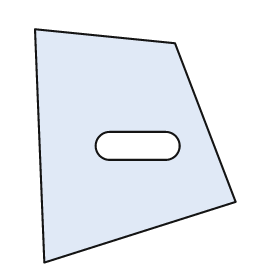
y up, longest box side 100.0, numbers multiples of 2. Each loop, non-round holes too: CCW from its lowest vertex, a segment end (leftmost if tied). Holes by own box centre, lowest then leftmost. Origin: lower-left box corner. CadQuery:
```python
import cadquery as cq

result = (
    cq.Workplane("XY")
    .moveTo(4.0, 0.0)
    .lineTo(86.0, 26.0)
    .lineTo(60.0, 94.0)
    .lineTo(0.0, 100.0)
    .close()
    .moveTo(32.0, 44.0)
    .lineTo(56.0, 44.0)
    .threePointArc((62.0, 50.0), (56.0, 56.0))
    .lineTo(32.0, 56.0)
    .threePointArc((26.0, 50.0), (32.0, 44.0))
    .close()
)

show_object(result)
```